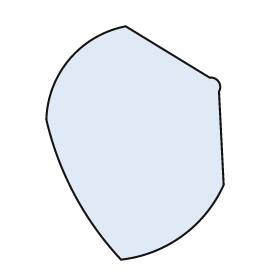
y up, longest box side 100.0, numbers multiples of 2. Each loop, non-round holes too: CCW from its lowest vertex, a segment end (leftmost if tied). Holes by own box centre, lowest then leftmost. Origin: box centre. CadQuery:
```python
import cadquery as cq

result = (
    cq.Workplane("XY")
    .moveTo(-6.0, -50.0)
    .threePointArc((20.0, -40.0), (38.0, -18.0))
    .lineTo(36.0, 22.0)
    .threePointArc((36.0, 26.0), (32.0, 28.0))
    .lineTo(-4.0, 50.0)
    .threePointArc((-28.0, 36.0), (-38.0, 10.0))
    .threePointArc((-26.0, -22.0), (-6.0, -50.0))
    .close()
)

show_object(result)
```